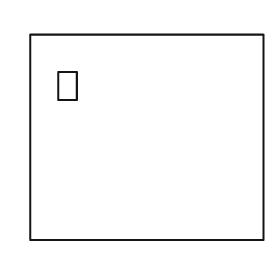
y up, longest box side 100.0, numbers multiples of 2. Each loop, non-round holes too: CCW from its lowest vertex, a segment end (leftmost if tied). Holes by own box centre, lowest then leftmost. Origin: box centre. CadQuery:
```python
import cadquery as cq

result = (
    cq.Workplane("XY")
    .moveTo(-50.0, -44.0)
    .lineTo(50.0, -44.0)
    .lineTo(50.0, 44.0)
    .lineTo(-50.0, 44.0)
    .close()
    .moveTo(-38.0, 16.0)
    .lineTo(-30.0, 16.0)
    .lineTo(-30.0, 28.0)
    .lineTo(-38.0, 28.0)
    .close()
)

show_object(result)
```